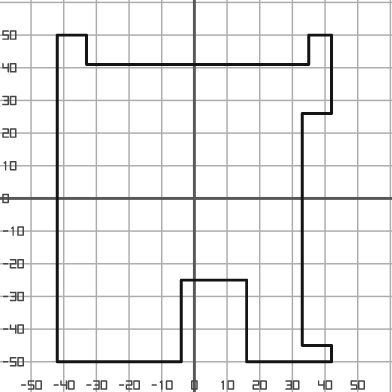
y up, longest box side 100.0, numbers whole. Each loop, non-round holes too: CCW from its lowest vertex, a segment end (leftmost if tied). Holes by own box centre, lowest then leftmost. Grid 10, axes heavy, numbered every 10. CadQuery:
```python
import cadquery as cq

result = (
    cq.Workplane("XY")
    .moveTo(-42.0, -50.0)
    .lineTo(-4.0, -50.0)
    .lineTo(-4.0, -25.0)
    .lineTo(16.0, -25.0)
    .lineTo(16.0, -50.0)
    .lineTo(42.0, -50.0)
    .lineTo(42.0, -45.0)
    .lineTo(33.0, -45.0)
    .lineTo(33.0, 26.0)
    .lineTo(42.0, 26.0)
    .lineTo(42.0, 50.0)
    .lineTo(35.0, 50.0)
    .lineTo(35.0, 41.0)
    .lineTo(-33.0, 41.0)
    .lineTo(-33.0, 50.0)
    .lineTo(-42.0, 50.0)
    .close()
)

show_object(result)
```